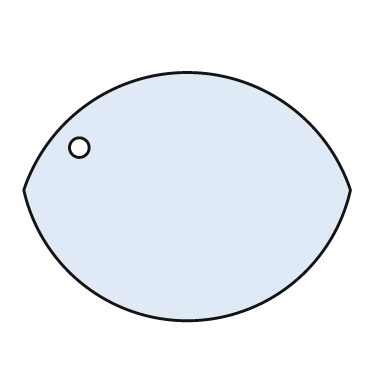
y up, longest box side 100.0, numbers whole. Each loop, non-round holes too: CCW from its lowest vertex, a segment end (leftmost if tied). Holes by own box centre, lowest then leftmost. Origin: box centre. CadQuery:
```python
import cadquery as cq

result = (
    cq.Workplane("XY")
    .moveTo(-50.0, 2.0)
    .threePointArc((0.0, -38.0), (50.0, 2.0))
    .threePointArc((0.0, 38.0), (-50.0, 2.0))
    .close()
    .moveTo(-33.0, 15.0)
    .circle(3.0)
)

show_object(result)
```